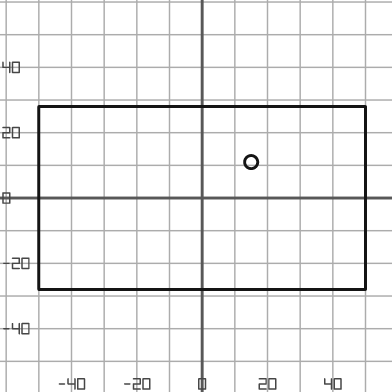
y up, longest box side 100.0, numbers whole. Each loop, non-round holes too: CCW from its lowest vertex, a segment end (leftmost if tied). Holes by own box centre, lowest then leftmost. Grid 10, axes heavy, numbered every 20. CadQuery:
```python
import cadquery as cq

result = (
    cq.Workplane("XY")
    .moveTo(-50.0, -28.0)
    .lineTo(50.0, -28.0)
    .lineTo(50.0, 28.0)
    .lineTo(-50.0, 28.0)
    .close()
    .moveTo(15.0, 11.0)
    .circle(2.0)
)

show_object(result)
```